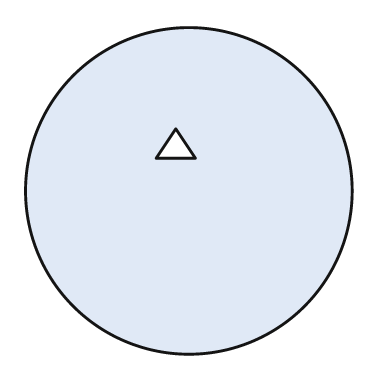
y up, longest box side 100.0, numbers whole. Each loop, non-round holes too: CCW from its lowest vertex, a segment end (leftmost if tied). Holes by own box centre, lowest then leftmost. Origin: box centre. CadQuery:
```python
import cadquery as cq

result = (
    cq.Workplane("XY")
    .moveTo(0.0, 0.0)
    .circle(50.0)
    .moveTo(-10.0, 10.0)
    .lineTo(2.0, 10.0)
    .lineTo(-4.0, 19.0)
    .close()
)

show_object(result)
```